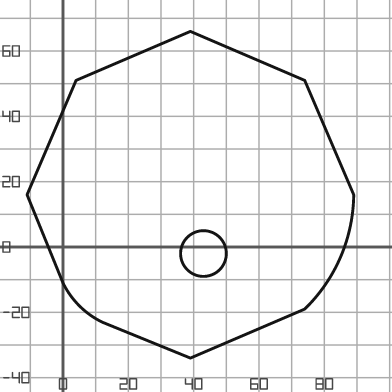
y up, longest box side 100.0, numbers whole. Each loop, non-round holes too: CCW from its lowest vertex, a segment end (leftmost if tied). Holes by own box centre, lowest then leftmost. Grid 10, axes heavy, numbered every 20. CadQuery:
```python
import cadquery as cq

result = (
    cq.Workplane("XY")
    .moveTo(39.0, -34.0)
    .lineTo(74.0, -19.0)
    .threePointArc((85.0, -3.0), (89.0, 16.0))
    .lineTo(74.0, 51.0)
    .lineTo(39.0, 66.0)
    .lineTo(4.0, 51.0)
    .lineTo(-11.0, 16.0)
    .lineTo(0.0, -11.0)
    .threePointArc((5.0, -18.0), (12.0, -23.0))
    .close()
    .moveTo(43.0, -2.0)
    .circle(7.0)
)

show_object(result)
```